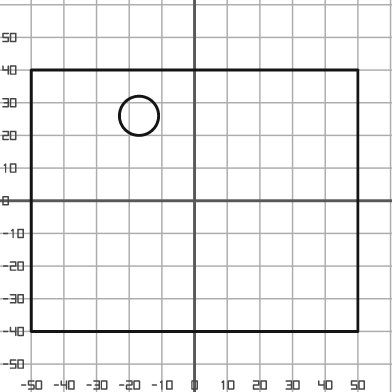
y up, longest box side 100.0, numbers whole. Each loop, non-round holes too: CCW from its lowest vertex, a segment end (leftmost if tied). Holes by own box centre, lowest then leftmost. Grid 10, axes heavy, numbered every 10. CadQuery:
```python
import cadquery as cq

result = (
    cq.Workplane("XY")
    .moveTo(-50.0, -40.0)
    .lineTo(50.0, -40.0)
    .lineTo(50.0, 40.0)
    .lineTo(-50.0, 40.0)
    .close()
    .moveTo(-17.0, 26.0)
    .circle(6.0)
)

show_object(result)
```